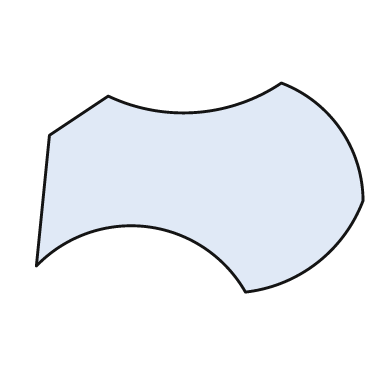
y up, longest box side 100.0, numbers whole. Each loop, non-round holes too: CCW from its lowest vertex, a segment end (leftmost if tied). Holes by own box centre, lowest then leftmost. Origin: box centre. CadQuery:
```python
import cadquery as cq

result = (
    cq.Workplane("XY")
    .moveTo(14.0, -32.0)
    .threePointArc((36.0, -23.0), (50.0, -4.0))
    .threePointArc((43.0, 18.0), (25.0, 32.0))
    .threePointArc((-1.0, 23.0), (-28.0, 28.0))
    .lineTo(-46.0, 16.0)
    .lineTo(-50.0, -24.0)
    .threePointArc((-16.0, -12.0), (14.0, -32.0))
    .close()
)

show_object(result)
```